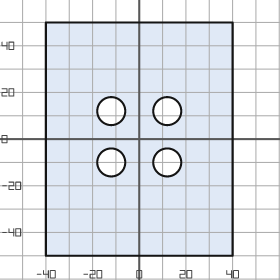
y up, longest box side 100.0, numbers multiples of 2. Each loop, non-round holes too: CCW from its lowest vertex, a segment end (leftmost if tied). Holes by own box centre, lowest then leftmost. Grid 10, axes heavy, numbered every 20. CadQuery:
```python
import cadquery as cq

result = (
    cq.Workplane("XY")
    .moveTo(-40.0, -50.0)
    .lineTo(40.0, -50.0)
    .lineTo(40.0, 50.0)
    .lineTo(-40.0, 50.0)
    .close()
    .moveTo(-12.0, -10.0)
    .circle(6.0)
    .moveTo(12.0, -10.0)
    .circle(6.0)
    .moveTo(-12.0, 12.0)
    .circle(6.0)
    .moveTo(12.0, 12.0)
    .circle(6.0)
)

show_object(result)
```